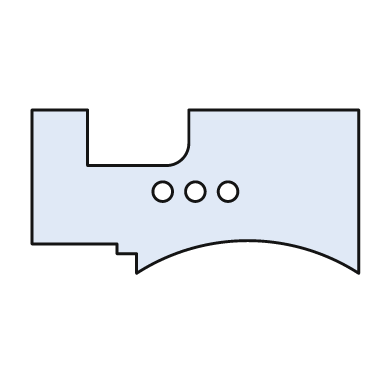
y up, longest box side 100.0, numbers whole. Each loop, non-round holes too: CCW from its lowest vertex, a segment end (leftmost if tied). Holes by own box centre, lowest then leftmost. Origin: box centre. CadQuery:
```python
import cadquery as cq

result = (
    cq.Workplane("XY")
    .moveTo(-18.0, -25.0)
    .threePointArc((16.0, -15.0), (50.0, -25.0))
    .lineTo(50.0, 25.0)
    .lineTo(-2.0, 25.0)
    .lineTo(-2.0, 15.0)
    .threePointArc((-4.0, 10.0), (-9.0, 8.0))
    .lineTo(-33.0, 8.0)
    .lineTo(-33.0, 25.0)
    .lineTo(-50.0, 25.0)
    .lineTo(-50.0, -16.0)
    .lineTo(-24.0, -16.0)
    .lineTo(-24.0, -19.0)
    .lineTo(-18.0, -19.0)
    .close()
    .moveTo(-10.0, 0.0)
    .circle(3.0)
    .moveTo(0.0, 0.0)
    .circle(3.0)
    .moveTo(10.0, 0.0)
    .circle(3.0)
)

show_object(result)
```